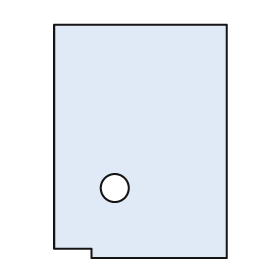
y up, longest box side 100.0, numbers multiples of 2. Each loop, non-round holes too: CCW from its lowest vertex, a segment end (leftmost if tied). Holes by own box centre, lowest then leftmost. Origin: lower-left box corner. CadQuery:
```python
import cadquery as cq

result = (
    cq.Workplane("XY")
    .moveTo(16.0, 0.0)
    .lineTo(74.0, 0.0)
    .lineTo(74.0, 100.0)
    .lineTo(0.0, 100.0)
    .lineTo(0.0, 4.0)
    .lineTo(16.0, 4.0)
    .close()
    .moveTo(26.0, 30.0)
    .circle(6.0)
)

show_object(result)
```